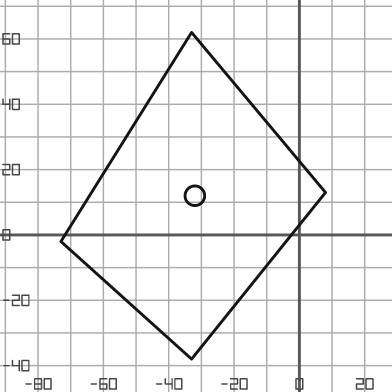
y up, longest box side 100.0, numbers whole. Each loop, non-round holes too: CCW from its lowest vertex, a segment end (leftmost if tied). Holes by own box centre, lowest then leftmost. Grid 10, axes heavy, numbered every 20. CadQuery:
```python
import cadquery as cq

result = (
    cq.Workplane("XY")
    .moveTo(-33.0, -38.0)
    .lineTo(8.0, 13.0)
    .lineTo(-33.0, 62.0)
    .lineTo(-73.0, -2.0)
    .close()
    .moveTo(-32.0, 12.0)
    .circle(3.0)
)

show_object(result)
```